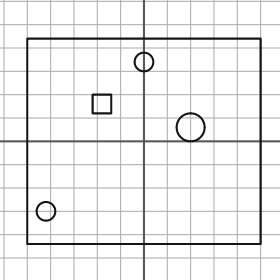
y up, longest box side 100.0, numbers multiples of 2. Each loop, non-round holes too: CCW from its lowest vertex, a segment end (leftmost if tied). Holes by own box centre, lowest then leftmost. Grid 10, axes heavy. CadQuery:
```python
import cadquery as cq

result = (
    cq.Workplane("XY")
    .moveTo(-50.0, -44.0)
    .lineTo(50.0, -44.0)
    .lineTo(50.0, 44.0)
    .lineTo(-50.0, 44.0)
    .close()
    .moveTo(-42.0, -30.0)
    .circle(4.0)
    .moveTo(20.0, 6.0)
    .circle(6.0)
    .moveTo(-22.0, 12.0)
    .lineTo(-14.0, 12.0)
    .lineTo(-14.0, 20.0)
    .lineTo(-22.0, 20.0)
    .close()
    .moveTo(0.0, 34.0)
    .circle(4.0)
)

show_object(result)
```